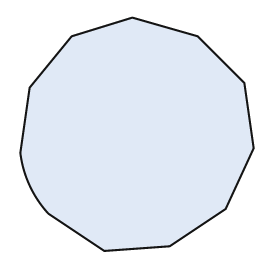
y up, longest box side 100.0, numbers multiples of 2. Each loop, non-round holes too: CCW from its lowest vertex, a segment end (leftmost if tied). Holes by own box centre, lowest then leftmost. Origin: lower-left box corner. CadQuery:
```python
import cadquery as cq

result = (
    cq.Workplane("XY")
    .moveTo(36.0, 0.0)
    .lineTo(64.0, 2.0)
    .lineTo(88.0, 18.0)
    .lineTo(100.0, 44.0)
    .lineTo(96.0, 72.0)
    .lineTo(76.0, 92.0)
    .lineTo(48.0, 100.0)
    .lineTo(22.0, 92.0)
    .lineTo(4.0, 70.0)
    .lineTo(0.0, 42.0)
    .threePointArc((4.0, 28.0), (12.0, 16.0))
    .close()
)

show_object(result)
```